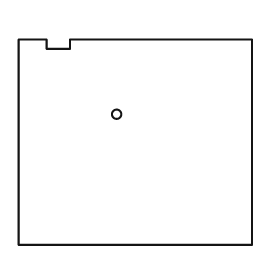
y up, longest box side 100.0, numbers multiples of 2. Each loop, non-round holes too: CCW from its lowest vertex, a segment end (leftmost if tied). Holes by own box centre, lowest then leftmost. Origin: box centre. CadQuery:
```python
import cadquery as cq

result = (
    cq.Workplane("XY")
    .moveTo(-50.0, -44.0)
    .lineTo(50.0, -44.0)
    .lineTo(50.0, 44.0)
    .lineTo(-28.0, 44.0)
    .lineTo(-28.0, 40.0)
    .lineTo(-38.0, 40.0)
    .lineTo(-38.0, 44.0)
    .lineTo(-50.0, 44.0)
    .close()
    .moveTo(-8.0, 12.0)
    .circle(2.0)
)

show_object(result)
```